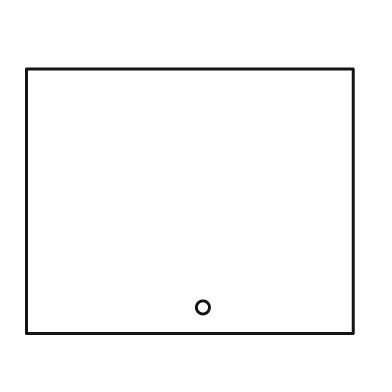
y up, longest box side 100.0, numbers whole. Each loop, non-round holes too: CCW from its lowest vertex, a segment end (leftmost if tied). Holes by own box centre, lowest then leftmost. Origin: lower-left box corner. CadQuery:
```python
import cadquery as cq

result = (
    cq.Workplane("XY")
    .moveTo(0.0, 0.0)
    .lineTo(100.0, 0.0)
    .lineTo(100.0, 81.0)
    .lineTo(0.0, 81.0)
    .close()
    .moveTo(54.0, 8.0)
    .circle(2.0)
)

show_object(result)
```